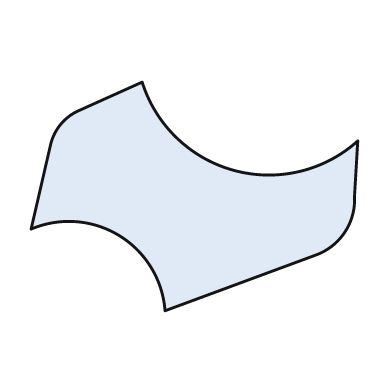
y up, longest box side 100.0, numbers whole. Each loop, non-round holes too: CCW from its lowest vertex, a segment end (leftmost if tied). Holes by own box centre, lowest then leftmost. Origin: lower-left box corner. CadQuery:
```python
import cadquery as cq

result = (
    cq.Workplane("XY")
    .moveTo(41.0, 0.0)
    .lineTo(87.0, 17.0)
    .threePointArc((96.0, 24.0), (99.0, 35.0))
    .lineTo(100.0, 52.0)
    .threePointArc((62.0, 43.0), (34.0, 70.0))
    .lineTo(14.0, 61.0)
    .threePointArc((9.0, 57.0), (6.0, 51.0))
    .lineTo(0.0, 25.0)
    .threePointArc((27.0, 23.0), (41.0, 0.0))
    .close()
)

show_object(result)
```